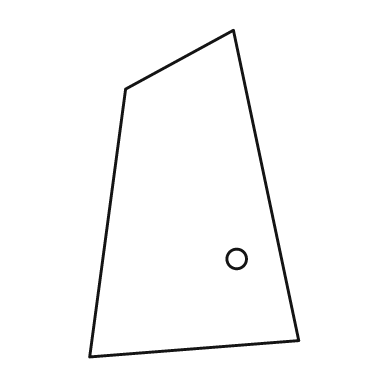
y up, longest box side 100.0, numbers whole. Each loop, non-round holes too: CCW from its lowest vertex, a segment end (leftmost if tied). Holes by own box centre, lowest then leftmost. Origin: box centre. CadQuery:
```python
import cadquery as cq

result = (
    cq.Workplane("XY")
    .moveTo(-32.0, -50.0)
    .lineTo(32.0, -45.0)
    .lineTo(12.0, 50.0)
    .lineTo(-21.0, 32.0)
    .close()
    .moveTo(13.0, -20.0)
    .circle(3.0)
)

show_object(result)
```